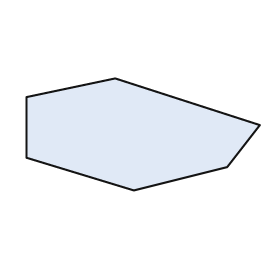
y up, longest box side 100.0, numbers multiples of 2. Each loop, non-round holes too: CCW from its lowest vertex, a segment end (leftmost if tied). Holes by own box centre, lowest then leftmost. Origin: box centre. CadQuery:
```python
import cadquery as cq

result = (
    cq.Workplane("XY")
    .moveTo(-4.0, -24.0)
    .lineTo(36.0, -14.0)
    .lineTo(50.0, 4.0)
    .lineTo(-12.0, 24.0)
    .lineTo(-50.0, 16.0)
    .lineTo(-50.0, -10.0)
    .close()
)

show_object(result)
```